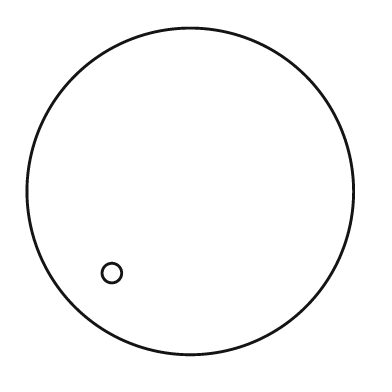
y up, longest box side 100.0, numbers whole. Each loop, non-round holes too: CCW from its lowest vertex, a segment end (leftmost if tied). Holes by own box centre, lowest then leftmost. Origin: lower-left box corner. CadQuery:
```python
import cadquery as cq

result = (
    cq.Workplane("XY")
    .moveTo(50.0, 50.0)
    .circle(50.0)
    .moveTo(26.0, 25.0)
    .circle(3.0)
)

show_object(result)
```